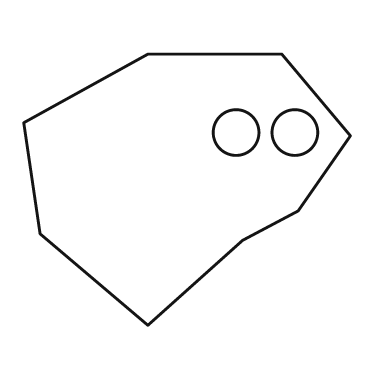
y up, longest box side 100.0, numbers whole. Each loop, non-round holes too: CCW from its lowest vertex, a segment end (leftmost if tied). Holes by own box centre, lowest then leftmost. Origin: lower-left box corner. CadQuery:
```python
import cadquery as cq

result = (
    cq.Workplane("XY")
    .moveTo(38.0, 0.0)
    .lineTo(67.0, 26.0)
    .lineTo(84.0, 35.0)
    .lineTo(100.0, 58.0)
    .lineTo(79.0, 83.0)
    .lineTo(38.0, 83.0)
    .lineTo(0.0, 62.0)
    .lineTo(5.0, 28.0)
    .close()
    .moveTo(65.0, 59.0)
    .circle(7.0)
    .moveTo(83.0, 59.0)
    .circle(7.0)
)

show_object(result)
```